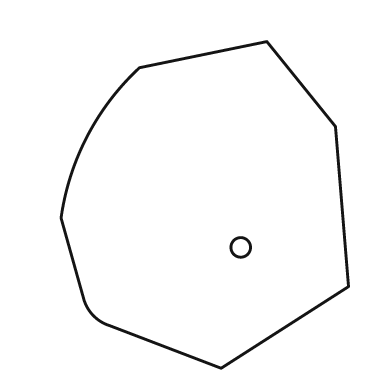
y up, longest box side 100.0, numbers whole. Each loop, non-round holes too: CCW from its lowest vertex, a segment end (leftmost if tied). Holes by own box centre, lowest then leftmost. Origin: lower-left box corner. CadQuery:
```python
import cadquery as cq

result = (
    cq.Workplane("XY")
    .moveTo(49.0, 0.0)
    .lineTo(88.0, 25.0)
    .lineTo(84.0, 74.0)
    .lineTo(63.0, 100.0)
    .lineTo(24.0, 92.0)
    .threePointArc((8.0, 71.0), (0.0, 46.0))
    .lineTo(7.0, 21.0)
    .threePointArc((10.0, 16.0), (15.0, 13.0))
    .close()
    .moveTo(55.0, 37.0)
    .circle(3.0)
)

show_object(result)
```